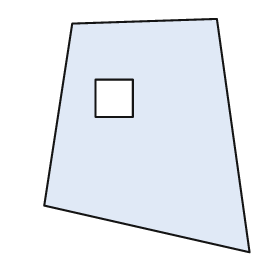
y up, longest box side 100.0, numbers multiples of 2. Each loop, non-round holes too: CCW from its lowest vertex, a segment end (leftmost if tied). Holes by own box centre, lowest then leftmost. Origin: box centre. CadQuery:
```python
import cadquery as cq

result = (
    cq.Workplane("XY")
    .moveTo(44.0, -50.0)
    .lineTo(30.0, 50.0)
    .lineTo(-32.0, 48.0)
    .lineTo(-44.0, -30.0)
    .close()
    .moveTo(-22.0, 8.0)
    .lineTo(-6.0, 8.0)
    .lineTo(-6.0, 24.0)
    .lineTo(-22.0, 24.0)
    .close()
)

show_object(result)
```